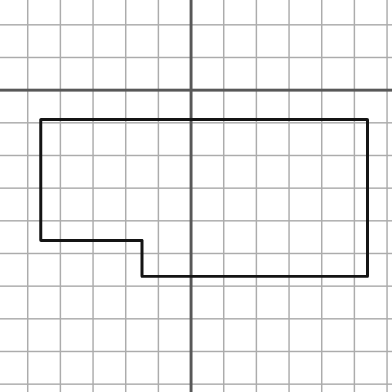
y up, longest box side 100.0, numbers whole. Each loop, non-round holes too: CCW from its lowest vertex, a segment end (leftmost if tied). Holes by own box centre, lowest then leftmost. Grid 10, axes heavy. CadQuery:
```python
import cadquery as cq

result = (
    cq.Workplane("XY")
    .moveTo(-15.0, -57.0)
    .lineTo(54.0, -57.0)
    .lineTo(54.0, -9.0)
    .lineTo(-46.0, -9.0)
    .lineTo(-46.0, -46.0)
    .lineTo(-15.0, -46.0)
    .close()
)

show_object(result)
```